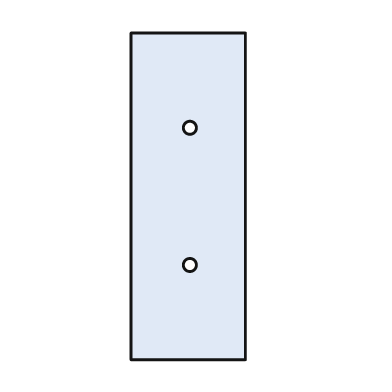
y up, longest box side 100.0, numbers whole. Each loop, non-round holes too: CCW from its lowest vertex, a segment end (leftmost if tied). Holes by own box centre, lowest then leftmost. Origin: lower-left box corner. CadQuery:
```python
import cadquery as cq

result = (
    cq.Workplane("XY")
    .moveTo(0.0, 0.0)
    .lineTo(35.0, 0.0)
    .lineTo(35.0, 100.0)
    .lineTo(0.0, 100.0)
    .close()
    .moveTo(18.0, 29.0)
    .circle(2.0)
    .moveTo(18.0, 71.0)
    .circle(2.0)
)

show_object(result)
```